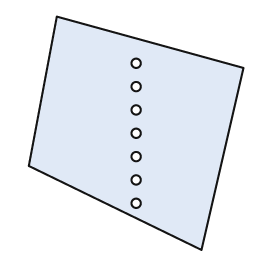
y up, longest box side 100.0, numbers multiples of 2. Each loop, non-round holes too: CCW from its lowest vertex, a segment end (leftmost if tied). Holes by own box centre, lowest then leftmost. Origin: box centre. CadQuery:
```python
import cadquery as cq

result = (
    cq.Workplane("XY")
    .moveTo(28.0, -50.0)
    .lineTo(46.0, 28.0)
    .lineTo(-34.0, 50.0)
    .lineTo(-46.0, -14.0)
    .close()
    .moveTo(0.0, -30.0)
    .circle(2.0)
    .moveTo(0.0, -20.0)
    .circle(2.0)
    .moveTo(0.0, -10.0)
    .circle(2.0)
    .moveTo(0.0, 0.0)
    .circle(2.0)
    .moveTo(0.0, 10.0)
    .circle(2.0)
    .moveTo(0.0, 20.0)
    .circle(2.0)
    .moveTo(0.0, 30.0)
    .circle(2.0)
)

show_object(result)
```